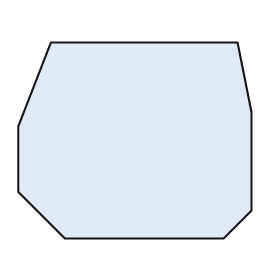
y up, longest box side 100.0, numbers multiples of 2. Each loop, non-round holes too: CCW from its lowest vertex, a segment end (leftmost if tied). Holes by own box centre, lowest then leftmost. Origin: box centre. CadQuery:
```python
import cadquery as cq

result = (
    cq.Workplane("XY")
    .moveTo(-30.0, -42.0)
    .lineTo(38.0, -42.0)
    .lineTo(50.0, -30.0)
    .lineTo(50.0, 12.0)
    .lineTo(44.0, 42.0)
    .lineTo(-36.0, 42.0)
    .lineTo(-50.0, 6.0)
    .lineTo(-50.0, -22.0)
    .close()
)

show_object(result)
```